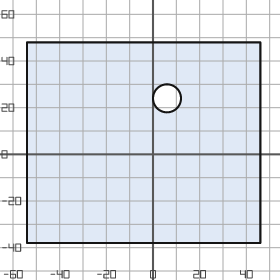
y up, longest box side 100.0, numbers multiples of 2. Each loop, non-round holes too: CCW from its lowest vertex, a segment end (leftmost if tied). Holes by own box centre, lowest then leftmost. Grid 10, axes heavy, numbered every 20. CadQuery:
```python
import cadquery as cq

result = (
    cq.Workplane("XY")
    .moveTo(-54.0, -38.0)
    .lineTo(46.0, -38.0)
    .lineTo(46.0, 48.0)
    .lineTo(-54.0, 48.0)
    .close()
    .moveTo(6.0, 24.0)
    .circle(6.0)
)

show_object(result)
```